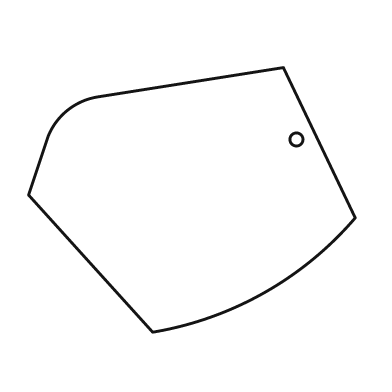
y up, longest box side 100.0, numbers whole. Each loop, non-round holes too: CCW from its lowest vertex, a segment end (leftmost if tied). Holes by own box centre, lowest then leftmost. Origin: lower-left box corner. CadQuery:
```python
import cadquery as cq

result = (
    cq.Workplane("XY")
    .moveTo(38.0, 0.0)
    .threePointArc((72.0, 12.0), (100.0, 35.0))
    .lineTo(78.0, 81.0)
    .lineTo(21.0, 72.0)
    .threePointArc((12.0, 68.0), (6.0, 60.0))
    .lineTo(0.0, 42.0)
    .close()
    .moveTo(82.0, 59.0)
    .circle(2.0)
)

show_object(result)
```